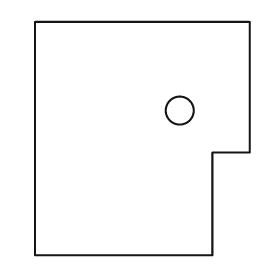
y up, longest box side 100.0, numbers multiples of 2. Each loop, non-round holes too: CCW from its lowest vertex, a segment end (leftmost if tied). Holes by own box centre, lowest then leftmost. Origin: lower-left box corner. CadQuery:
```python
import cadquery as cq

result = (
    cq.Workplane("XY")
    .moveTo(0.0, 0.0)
    .lineTo(76.0, 0.0)
    .lineTo(76.0, 44.0)
    .lineTo(92.0, 44.0)
    .lineTo(92.0, 100.0)
    .lineTo(0.0, 100.0)
    .close()
    .moveTo(62.0, 62.0)
    .circle(6.0)
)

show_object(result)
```